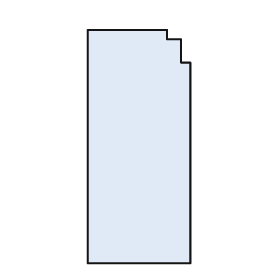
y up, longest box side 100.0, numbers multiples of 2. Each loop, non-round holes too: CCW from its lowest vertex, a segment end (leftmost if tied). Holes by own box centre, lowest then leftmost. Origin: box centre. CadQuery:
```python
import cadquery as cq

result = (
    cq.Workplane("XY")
    .moveTo(-22.0, -50.0)
    .lineTo(22.0, -50.0)
    .lineTo(22.0, 36.0)
    .lineTo(18.0, 36.0)
    .lineTo(18.0, 46.0)
    .lineTo(12.0, 46.0)
    .lineTo(12.0, 50.0)
    .lineTo(-22.0, 50.0)
    .close()
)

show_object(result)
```